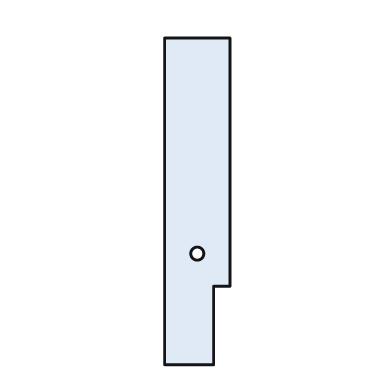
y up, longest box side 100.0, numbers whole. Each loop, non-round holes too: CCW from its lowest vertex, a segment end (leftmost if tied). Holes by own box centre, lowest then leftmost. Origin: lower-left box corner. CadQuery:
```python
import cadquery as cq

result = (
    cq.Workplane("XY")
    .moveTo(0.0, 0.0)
    .lineTo(15.0, 0.0)
    .lineTo(15.0, 24.0)
    .lineTo(20.0, 24.0)
    .lineTo(20.0, 100.0)
    .lineTo(0.0, 100.0)
    .close()
    .moveTo(10.0, 34.0)
    .circle(2.0)
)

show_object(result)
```